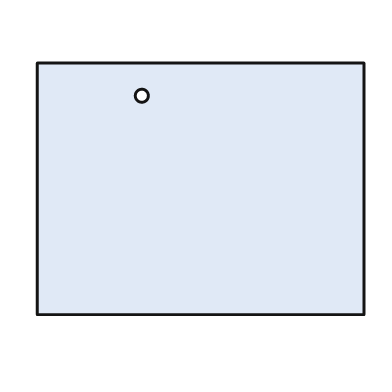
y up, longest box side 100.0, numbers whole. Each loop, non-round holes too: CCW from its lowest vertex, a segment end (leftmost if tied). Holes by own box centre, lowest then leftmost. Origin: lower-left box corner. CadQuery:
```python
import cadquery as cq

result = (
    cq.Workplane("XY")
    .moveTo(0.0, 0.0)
    .lineTo(100.0, 0.0)
    .lineTo(100.0, 77.0)
    .lineTo(0.0, 77.0)
    .close()
    .moveTo(32.0, 67.0)
    .circle(2.0)
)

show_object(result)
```